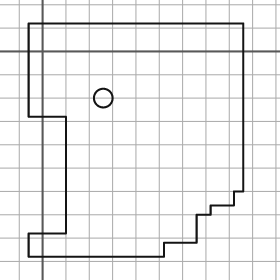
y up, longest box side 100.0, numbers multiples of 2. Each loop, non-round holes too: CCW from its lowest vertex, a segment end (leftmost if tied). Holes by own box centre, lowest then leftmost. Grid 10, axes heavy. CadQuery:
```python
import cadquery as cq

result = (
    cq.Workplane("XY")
    .moveTo(-6.0, -88.0)
    .lineTo(52.0, -88.0)
    .lineTo(52.0, -82.0)
    .lineTo(66.0, -82.0)
    .lineTo(66.0, -70.0)
    .lineTo(72.0, -70.0)
    .lineTo(72.0, -66.0)
    .lineTo(82.0, -66.0)
    .lineTo(82.0, -60.0)
    .lineTo(86.0, -60.0)
    .lineTo(86.0, 12.0)
    .lineTo(-6.0, 12.0)
    .lineTo(-6.0, -28.0)
    .lineTo(10.0, -28.0)
    .lineTo(10.0, -78.0)
    .lineTo(-6.0, -78.0)
    .close()
    .moveTo(26.0, -20.0)
    .circle(4.0)
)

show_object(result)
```